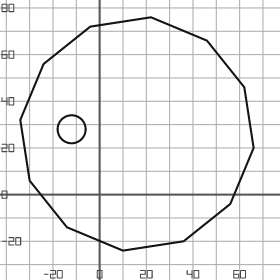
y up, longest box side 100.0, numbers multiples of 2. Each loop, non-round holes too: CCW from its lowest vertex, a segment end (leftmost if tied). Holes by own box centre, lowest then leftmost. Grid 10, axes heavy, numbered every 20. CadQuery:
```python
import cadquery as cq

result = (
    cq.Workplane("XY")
    .moveTo(10.0, -24.0)
    .lineTo(36.0, -20.0)
    .lineTo(56.0, -4.0)
    .lineTo(66.0, 20.0)
    .lineTo(62.0, 46.0)
    .lineTo(46.0, 66.0)
    .lineTo(22.0, 76.0)
    .lineTo(-4.0, 72.0)
    .lineTo(-24.0, 56.0)
    .lineTo(-34.0, 32.0)
    .lineTo(-30.0, 6.0)
    .lineTo(-14.0, -14.0)
    .close()
    .moveTo(-12.0, 28.0)
    .circle(6.0)
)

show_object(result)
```